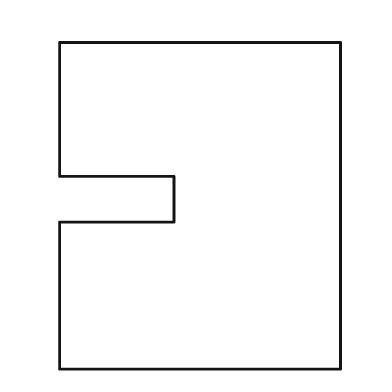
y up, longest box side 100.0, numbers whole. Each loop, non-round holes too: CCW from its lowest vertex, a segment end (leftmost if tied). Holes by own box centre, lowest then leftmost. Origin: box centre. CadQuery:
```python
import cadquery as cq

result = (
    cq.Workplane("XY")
    .moveTo(-43.0, -50.0)
    .lineTo(43.0, -50.0)
    .lineTo(43.0, 50.0)
    .lineTo(-43.0, 50.0)
    .lineTo(-43.0, 9.0)
    .lineTo(-8.0, 9.0)
    .lineTo(-8.0, -5.0)
    .lineTo(-43.0, -5.0)
    .close()
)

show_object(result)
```